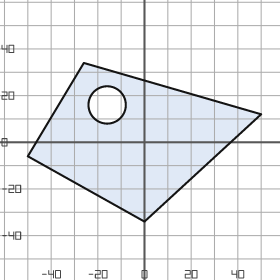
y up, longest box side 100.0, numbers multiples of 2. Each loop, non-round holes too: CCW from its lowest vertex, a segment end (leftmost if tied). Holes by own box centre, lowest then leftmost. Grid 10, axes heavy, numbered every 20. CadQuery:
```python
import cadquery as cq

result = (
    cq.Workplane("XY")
    .moveTo(0.0, -34.0)
    .lineTo(50.0, 12.0)
    .lineTo(-26.0, 34.0)
    .lineTo(-50.0, -6.0)
    .close()
    .moveTo(-16.0, 16.0)
    .circle(8.0)
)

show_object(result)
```